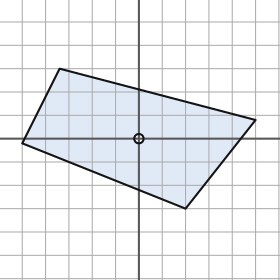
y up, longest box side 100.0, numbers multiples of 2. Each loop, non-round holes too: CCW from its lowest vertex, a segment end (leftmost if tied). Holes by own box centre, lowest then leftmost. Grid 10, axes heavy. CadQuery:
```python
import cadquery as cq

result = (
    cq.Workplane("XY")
    .moveTo(20.0, -30.0)
    .lineTo(50.0, 8.0)
    .lineTo(-34.0, 30.0)
    .lineTo(-50.0, -2.0)
    .close()
    .moveTo(0.0, 0.0)
    .circle(2.0)
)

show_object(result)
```